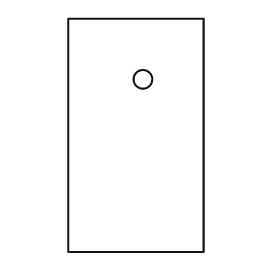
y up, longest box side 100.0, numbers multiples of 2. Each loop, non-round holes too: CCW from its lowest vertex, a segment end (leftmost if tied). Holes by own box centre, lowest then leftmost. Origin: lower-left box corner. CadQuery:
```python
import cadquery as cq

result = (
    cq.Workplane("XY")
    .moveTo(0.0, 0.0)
    .lineTo(58.0, 0.0)
    .lineTo(58.0, 100.0)
    .lineTo(0.0, 100.0)
    .close()
    .moveTo(32.0, 74.0)
    .circle(4.0)
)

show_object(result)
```